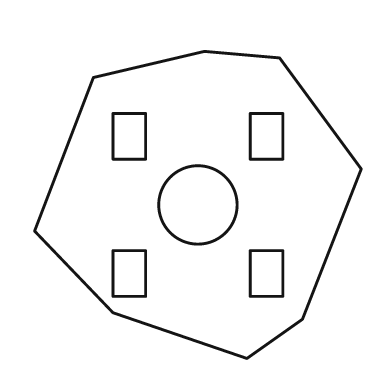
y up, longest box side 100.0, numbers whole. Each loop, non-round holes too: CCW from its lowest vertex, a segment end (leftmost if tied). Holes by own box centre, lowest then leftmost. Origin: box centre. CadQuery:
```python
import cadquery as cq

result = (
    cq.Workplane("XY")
    .moveTo(15.0, -47.0)
    .lineTo(32.0, -35.0)
    .lineTo(50.0, 11.0)
    .lineTo(25.0, 45.0)
    .lineTo(2.0, 47.0)
    .lineTo(-32.0, 39.0)
    .lineTo(-50.0, -8.0)
    .lineTo(-26.0, -33.0)
    .close()
    .moveTo(-26.0, -28.0)
    .lineTo(-16.0, -28.0)
    .lineTo(-16.0, -14.0)
    .lineTo(-26.0, -14.0)
    .close()
    .moveTo(16.0, -28.0)
    .lineTo(26.0, -28.0)
    .lineTo(26.0, -14.0)
    .lineTo(16.0, -14.0)
    .close()
    .moveTo(0.0, 0.0)
    .circle(12.0)
    .moveTo(-26.0, 14.0)
    .lineTo(-16.0, 14.0)
    .lineTo(-16.0, 28.0)
    .lineTo(-26.0, 28.0)
    .close()
    .moveTo(16.0, 14.0)
    .lineTo(26.0, 14.0)
    .lineTo(26.0, 28.0)
    .lineTo(16.0, 28.0)
    .close()
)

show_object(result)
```